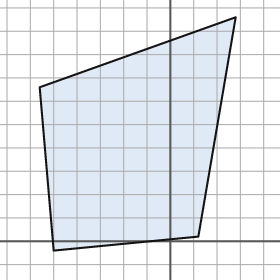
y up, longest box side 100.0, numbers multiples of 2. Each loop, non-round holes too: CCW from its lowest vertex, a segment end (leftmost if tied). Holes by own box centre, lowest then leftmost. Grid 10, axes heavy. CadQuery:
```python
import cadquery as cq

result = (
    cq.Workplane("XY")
    .moveTo(-50.0, -4.0)
    .lineTo(12.0, 2.0)
    .lineTo(28.0, 96.0)
    .lineTo(-56.0, 66.0)
    .close()
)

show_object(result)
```